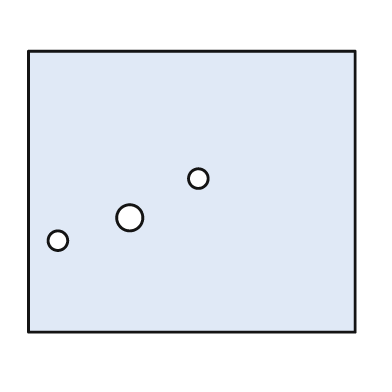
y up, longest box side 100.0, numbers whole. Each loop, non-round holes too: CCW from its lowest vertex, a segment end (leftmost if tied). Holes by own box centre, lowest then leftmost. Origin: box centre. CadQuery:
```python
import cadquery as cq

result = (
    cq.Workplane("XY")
    .moveTo(-50.0, -43.0)
    .lineTo(50.0, -43.0)
    .lineTo(50.0, 43.0)
    .lineTo(-50.0, 43.0)
    .close()
    .moveTo(-41.0, -15.0)
    .circle(3.0)
    .moveTo(-19.0, -8.0)
    .circle(4.0)
    .moveTo(2.0, 4.0)
    .circle(3.0)
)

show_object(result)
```